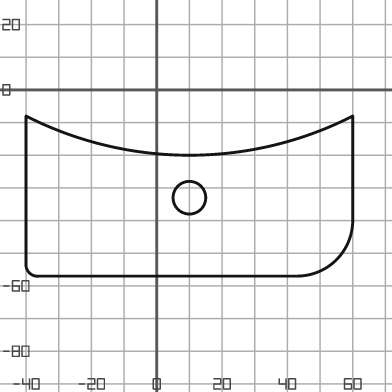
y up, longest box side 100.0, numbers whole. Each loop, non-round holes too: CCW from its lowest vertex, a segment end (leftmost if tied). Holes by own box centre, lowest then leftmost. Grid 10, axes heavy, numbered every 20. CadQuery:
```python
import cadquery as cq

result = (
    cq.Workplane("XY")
    .moveTo(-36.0, -57.0)
    .lineTo(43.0, -57.0)
    .threePointArc((55.0, -52.0), (60.0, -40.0))
    .lineTo(60.0, -8.0)
    .threePointArc((10.0, -20.0), (-40.0, -8.0))
    .lineTo(-40.0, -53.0)
    .threePointArc((-39.0, -56.0), (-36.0, -57.0))
    .close()
    .moveTo(10.0, -33.0)
    .circle(5.0)
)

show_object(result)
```